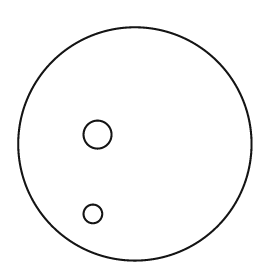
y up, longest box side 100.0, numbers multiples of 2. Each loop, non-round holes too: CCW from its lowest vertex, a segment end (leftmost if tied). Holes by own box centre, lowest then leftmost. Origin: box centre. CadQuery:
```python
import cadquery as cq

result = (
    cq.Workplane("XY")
    .moveTo(0.0, 0.0)
    .circle(50.0)
    .moveTo(-18.0, -30.0)
    .circle(4.0)
    .moveTo(-16.0, 4.0)
    .circle(6.0)
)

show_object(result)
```